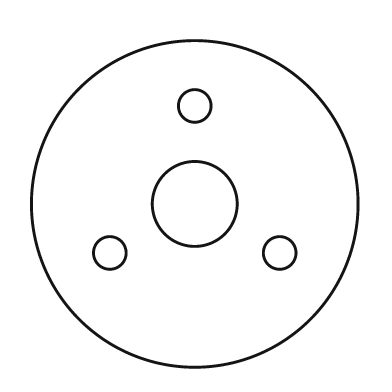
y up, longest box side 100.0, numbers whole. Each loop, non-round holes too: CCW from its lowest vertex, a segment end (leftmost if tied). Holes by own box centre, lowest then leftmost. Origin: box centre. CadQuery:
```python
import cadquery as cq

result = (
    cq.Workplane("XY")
    .moveTo(0.0, 0.0)
    .circle(50.0)
    .moveTo(-26.0, -15.0)
    .circle(5.0)
    .moveTo(26.0, -15.0)
    .circle(5.0)
    .moveTo(0.0, 0.0)
    .circle(13.0)
    .moveTo(0.0, 30.0)
    .circle(5.0)
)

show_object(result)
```